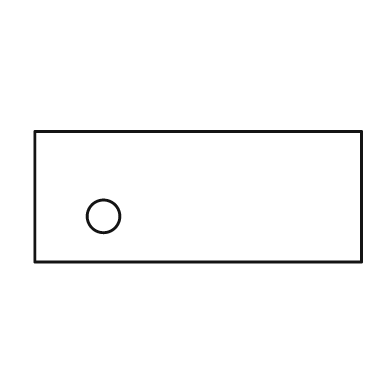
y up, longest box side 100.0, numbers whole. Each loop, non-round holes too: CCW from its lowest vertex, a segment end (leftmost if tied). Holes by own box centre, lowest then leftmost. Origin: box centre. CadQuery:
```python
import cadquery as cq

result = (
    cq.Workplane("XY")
    .moveTo(-50.0, -20.0)
    .lineTo(50.0, -20.0)
    .lineTo(50.0, 20.0)
    .lineTo(-50.0, 20.0)
    .close()
    .moveTo(-29.0, -6.0)
    .circle(5.0)
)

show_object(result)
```